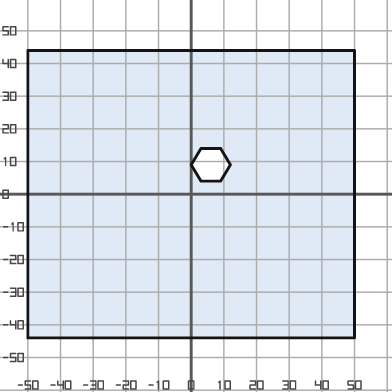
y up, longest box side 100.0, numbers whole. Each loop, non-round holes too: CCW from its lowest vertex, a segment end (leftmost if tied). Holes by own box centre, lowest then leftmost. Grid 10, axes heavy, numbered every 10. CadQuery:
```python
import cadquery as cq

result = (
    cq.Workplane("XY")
    .moveTo(-50.0, -44.0)
    .lineTo(50.0, -44.0)
    .lineTo(50.0, 44.0)
    .lineTo(-50.0, 44.0)
    .close()
    .moveTo(3.0, 4.0)
    .lineTo(9.0, 4.0)
    .lineTo(12.0, 9.0)
    .lineTo(9.0, 14.0)
    .lineTo(3.0, 14.0)
    .lineTo(0.0, 9.0)
    .close()
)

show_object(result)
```